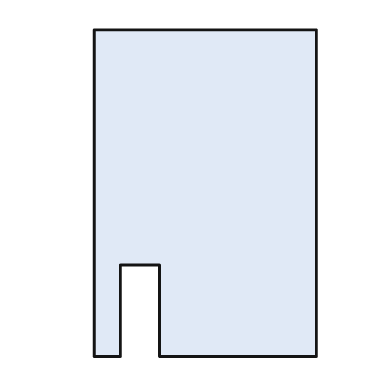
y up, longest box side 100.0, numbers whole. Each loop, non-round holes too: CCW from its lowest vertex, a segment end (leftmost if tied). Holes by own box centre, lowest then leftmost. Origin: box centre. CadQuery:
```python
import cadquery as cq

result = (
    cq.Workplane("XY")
    .moveTo(-34.0, -50.0)
    .lineTo(-26.0, -50.0)
    .lineTo(-26.0, -22.0)
    .lineTo(-14.0, -22.0)
    .lineTo(-14.0, -50.0)
    .lineTo(34.0, -50.0)
    .lineTo(34.0, 50.0)
    .lineTo(-34.0, 50.0)
    .close()
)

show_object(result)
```